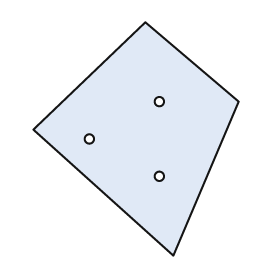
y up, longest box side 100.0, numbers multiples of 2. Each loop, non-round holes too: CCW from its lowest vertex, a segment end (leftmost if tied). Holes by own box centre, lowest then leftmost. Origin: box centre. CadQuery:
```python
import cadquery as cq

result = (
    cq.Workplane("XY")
    .moveTo(16.0, -50.0)
    .lineTo(44.0, 16.0)
    .lineTo(4.0, 50.0)
    .lineTo(-44.0, 4.0)
    .close()
    .moveTo(10.0, -16.0)
    .circle(2.0)
    .moveTo(-20.0, 0.0)
    .circle(2.0)
    .moveTo(10.0, 16.0)
    .circle(2.0)
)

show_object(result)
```